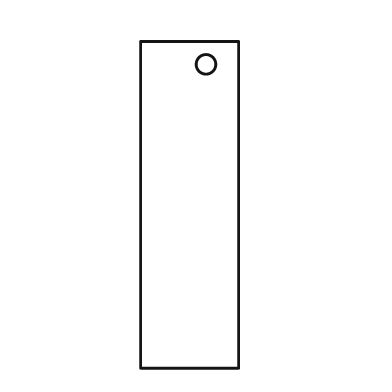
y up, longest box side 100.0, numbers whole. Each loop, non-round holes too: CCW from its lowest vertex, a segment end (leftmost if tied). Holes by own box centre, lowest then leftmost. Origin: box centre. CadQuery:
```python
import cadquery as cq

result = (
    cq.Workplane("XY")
    .moveTo(-15.0, -50.0)
    .lineTo(15.0, -50.0)
    .lineTo(15.0, 50.0)
    .lineTo(-15.0, 50.0)
    .close()
    .moveTo(5.0, 43.0)
    .circle(3.0)
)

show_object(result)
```